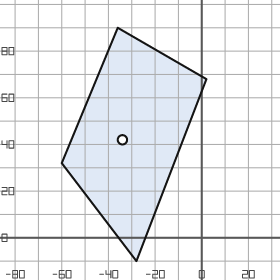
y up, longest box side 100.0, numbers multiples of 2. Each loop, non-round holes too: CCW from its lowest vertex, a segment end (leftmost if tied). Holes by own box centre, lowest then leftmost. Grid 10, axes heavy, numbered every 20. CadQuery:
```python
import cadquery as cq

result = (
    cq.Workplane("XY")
    .moveTo(-28.0, -10.0)
    .lineTo(2.0, 68.0)
    .lineTo(-36.0, 90.0)
    .lineTo(-60.0, 32.0)
    .close()
    .moveTo(-34.0, 42.0)
    .circle(2.0)
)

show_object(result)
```